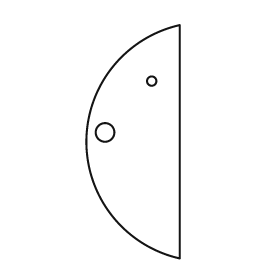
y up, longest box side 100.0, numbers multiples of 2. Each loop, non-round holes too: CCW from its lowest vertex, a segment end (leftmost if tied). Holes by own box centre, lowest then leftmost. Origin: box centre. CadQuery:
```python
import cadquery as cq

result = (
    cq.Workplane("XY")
    .moveTo(20.0, -50.0)
    .lineTo(20.0, 50.0)
    .threePointArc((-20.0, 0.0), (20.0, -50.0))
    .close()
    .moveTo(-12.0, 4.0)
    .circle(4.0)
    .moveTo(8.0, 26.0)
    .circle(2.0)
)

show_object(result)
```